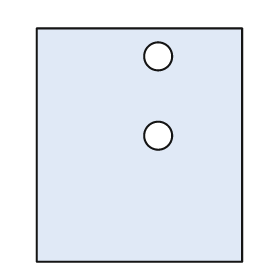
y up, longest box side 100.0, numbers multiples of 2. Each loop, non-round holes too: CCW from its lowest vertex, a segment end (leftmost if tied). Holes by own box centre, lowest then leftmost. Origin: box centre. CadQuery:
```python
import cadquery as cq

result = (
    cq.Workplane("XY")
    .moveTo(-44.0, -50.0)
    .lineTo(44.0, -50.0)
    .lineTo(44.0, 50.0)
    .lineTo(-44.0, 50.0)
    .close()
    .moveTo(8.0, 4.0)
    .circle(6.0)
    .moveTo(8.0, 38.0)
    .circle(6.0)
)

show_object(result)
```